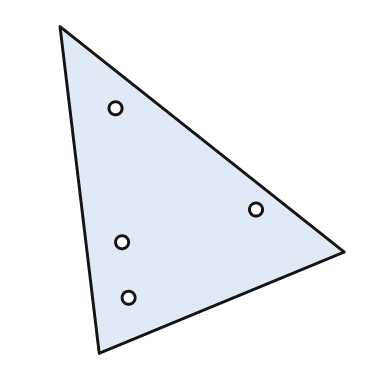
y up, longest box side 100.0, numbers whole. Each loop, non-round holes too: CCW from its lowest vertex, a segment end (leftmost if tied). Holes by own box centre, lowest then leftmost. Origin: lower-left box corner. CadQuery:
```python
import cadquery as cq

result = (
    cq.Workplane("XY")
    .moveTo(12.0, 0.0)
    .lineTo(87.0, 31.0)
    .lineTo(0.0, 100.0)
    .close()
    .moveTo(21.0, 17.0)
    .circle(2.0)
    .moveTo(19.0, 34.0)
    .circle(2.0)
    .moveTo(60.0, 44.0)
    .circle(2.0)
    .moveTo(17.0, 75.0)
    .circle(2.0)
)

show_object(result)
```